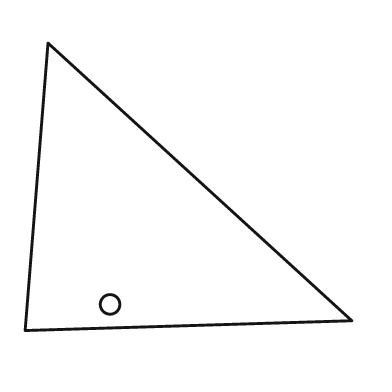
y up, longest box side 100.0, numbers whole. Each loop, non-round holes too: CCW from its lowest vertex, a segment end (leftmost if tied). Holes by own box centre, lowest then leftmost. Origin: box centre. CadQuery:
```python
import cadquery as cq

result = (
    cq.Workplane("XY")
    .moveTo(-50.0, -44.0)
    .lineTo(50.0, -41.0)
    .lineTo(-43.0, 44.0)
    .close()
    .moveTo(-24.0, -36.0)
    .circle(3.0)
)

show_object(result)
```